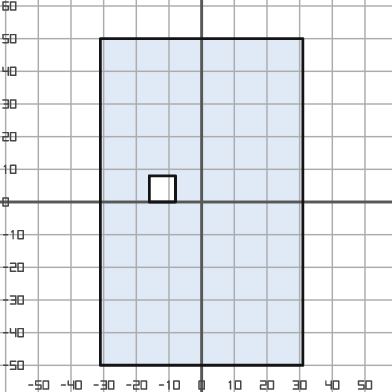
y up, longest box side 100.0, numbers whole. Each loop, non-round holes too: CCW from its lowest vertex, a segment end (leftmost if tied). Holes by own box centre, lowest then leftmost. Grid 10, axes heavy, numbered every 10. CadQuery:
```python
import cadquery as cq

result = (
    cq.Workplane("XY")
    .moveTo(-31.0, -50.0)
    .lineTo(31.0, -50.0)
    .lineTo(31.0, 50.0)
    .lineTo(-31.0, 50.0)
    .close()
    .moveTo(-16.0, 0.0)
    .lineTo(-8.0, 0.0)
    .lineTo(-8.0, 8.0)
    .lineTo(-16.0, 8.0)
    .close()
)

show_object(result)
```